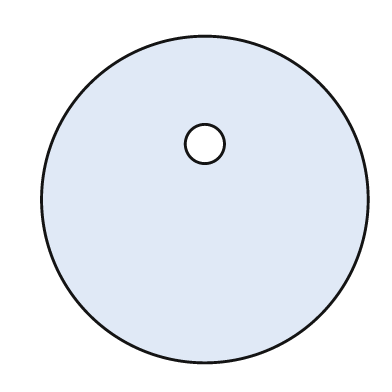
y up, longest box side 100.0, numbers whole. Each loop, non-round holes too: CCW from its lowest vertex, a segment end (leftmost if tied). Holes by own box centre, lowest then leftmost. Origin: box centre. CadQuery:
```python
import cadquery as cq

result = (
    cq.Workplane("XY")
    .moveTo(0.0, 0.0)
    .circle(50.0)
    .moveTo(0.0, 17.0)
    .circle(6.0)
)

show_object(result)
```